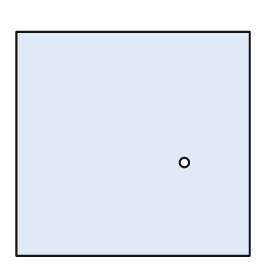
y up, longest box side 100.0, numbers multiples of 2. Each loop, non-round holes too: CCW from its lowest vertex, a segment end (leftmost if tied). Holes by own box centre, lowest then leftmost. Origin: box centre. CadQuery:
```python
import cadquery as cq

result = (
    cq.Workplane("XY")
    .moveTo(-50.0, -48.0)
    .lineTo(50.0, -48.0)
    .lineTo(50.0, 48.0)
    .lineTo(-50.0, 48.0)
    .close()
    .moveTo(22.0, -8.0)
    .circle(2.0)
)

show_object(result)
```